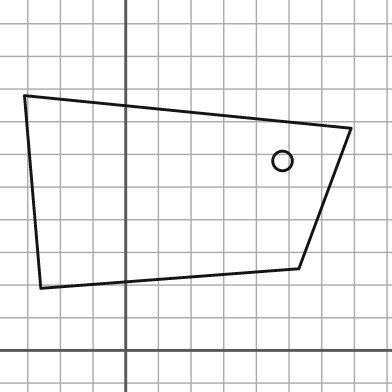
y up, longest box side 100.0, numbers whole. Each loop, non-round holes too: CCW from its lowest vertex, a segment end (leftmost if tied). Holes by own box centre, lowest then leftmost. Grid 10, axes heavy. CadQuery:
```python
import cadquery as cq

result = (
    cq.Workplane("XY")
    .moveTo(-26.0, 19.0)
    .lineTo(53.0, 25.0)
    .lineTo(69.0, 68.0)
    .lineTo(-31.0, 78.0)
    .close()
    .moveTo(48.0, 58.0)
    .circle(3.0)
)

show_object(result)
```